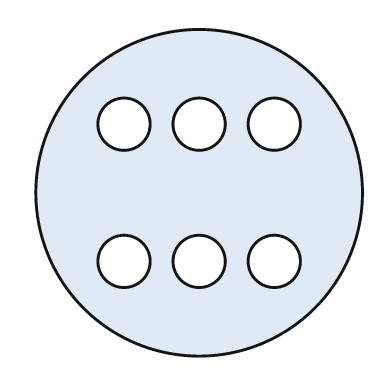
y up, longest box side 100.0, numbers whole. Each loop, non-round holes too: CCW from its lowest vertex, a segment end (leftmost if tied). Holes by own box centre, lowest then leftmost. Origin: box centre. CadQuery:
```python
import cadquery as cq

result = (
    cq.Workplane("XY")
    .moveTo(0.0, 0.0)
    .circle(50.0)
    .moveTo(-23.0, -21.0)
    .circle(8.0)
    .moveTo(0.0, -21.0)
    .circle(8.0)
    .moveTo(23.0, -21.0)
    .circle(8.0)
    .moveTo(-23.0, 21.0)
    .circle(8.0)
    .moveTo(0.0, 21.0)
    .circle(8.0)
    .moveTo(23.0, 21.0)
    .circle(8.0)
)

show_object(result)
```